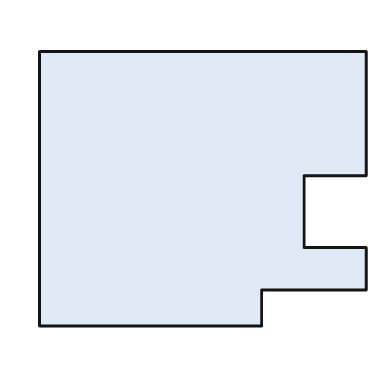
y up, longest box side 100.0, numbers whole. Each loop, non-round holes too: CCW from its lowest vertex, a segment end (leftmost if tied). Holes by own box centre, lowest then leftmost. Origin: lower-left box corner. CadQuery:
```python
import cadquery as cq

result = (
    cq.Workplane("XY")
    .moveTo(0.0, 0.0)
    .lineTo(68.0, 0.0)
    .lineTo(68.0, 11.0)
    .lineTo(100.0, 11.0)
    .lineTo(100.0, 24.0)
    .lineTo(81.0, 24.0)
    .lineTo(81.0, 46.0)
    .lineTo(100.0, 46.0)
    .lineTo(100.0, 84.0)
    .lineTo(0.0, 84.0)
    .close()
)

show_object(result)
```